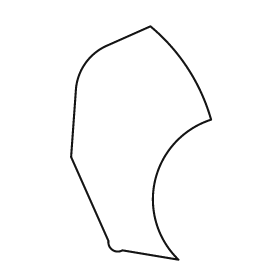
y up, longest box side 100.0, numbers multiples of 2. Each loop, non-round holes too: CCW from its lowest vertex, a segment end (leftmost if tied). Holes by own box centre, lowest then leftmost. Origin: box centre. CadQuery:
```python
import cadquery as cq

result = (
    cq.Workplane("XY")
    .moveTo(16.0, -50.0)
    .threePointArc((6.0, -16.0), (30.0, 10.0))
    .threePointArc((20.0, 32.0), (4.0, 50.0))
    .lineTo(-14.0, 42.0)
    .threePointArc((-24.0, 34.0), (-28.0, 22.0))
    .lineTo(-30.0, -6.0)
    .lineTo(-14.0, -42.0)
    .threePointArc((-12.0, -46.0), (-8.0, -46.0))
    .close()
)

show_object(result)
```